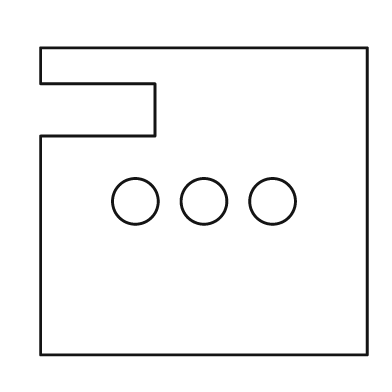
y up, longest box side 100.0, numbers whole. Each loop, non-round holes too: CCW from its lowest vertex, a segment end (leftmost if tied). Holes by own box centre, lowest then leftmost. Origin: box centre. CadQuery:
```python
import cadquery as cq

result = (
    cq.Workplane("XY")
    .moveTo(-50.0, -47.0)
    .lineTo(50.0, -47.0)
    .lineTo(50.0, 47.0)
    .lineTo(-50.0, 47.0)
    .lineTo(-50.0, 36.0)
    .lineTo(-15.0, 36.0)
    .lineTo(-15.0, 20.0)
    .lineTo(-50.0, 20.0)
    .close()
    .moveTo(-21.0, 0.0)
    .circle(7.0)
    .moveTo(0.0, 0.0)
    .circle(7.0)
    .moveTo(21.0, 0.0)
    .circle(7.0)
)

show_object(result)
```